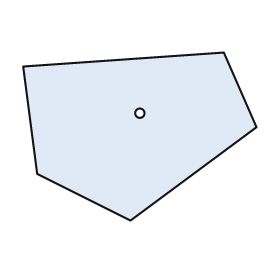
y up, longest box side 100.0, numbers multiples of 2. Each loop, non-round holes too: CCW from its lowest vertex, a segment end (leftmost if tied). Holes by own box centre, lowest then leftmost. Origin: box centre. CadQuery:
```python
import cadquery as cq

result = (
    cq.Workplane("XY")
    .moveTo(-4.0, -36.0)
    .lineTo(50.0, 4.0)
    .lineTo(36.0, 36.0)
    .lineTo(-50.0, 30.0)
    .lineTo(-44.0, -16.0)
    .close()
    .moveTo(0.0, 10.0)
    .circle(2.0)
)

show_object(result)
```